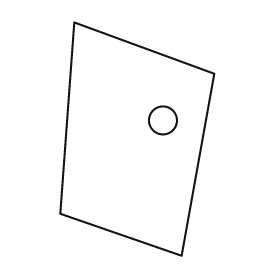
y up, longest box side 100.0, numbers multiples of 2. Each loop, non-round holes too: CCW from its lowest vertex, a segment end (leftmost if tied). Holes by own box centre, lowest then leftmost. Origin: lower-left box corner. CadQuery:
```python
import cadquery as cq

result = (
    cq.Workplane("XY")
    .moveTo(52.0, 0.0)
    .lineTo(66.0, 78.0)
    .lineTo(6.0, 100.0)
    .lineTo(0.0, 18.0)
    .close()
    .moveTo(44.0, 58.0)
    .circle(6.0)
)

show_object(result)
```